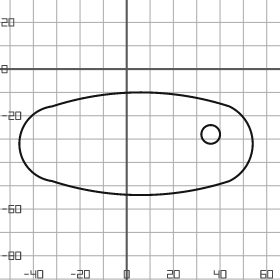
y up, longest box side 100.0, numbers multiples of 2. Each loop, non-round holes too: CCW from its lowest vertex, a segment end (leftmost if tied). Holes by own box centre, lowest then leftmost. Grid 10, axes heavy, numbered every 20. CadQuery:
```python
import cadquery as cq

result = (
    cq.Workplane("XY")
    .moveTo(-32.0, -48.0)
    .threePointArc((6.0, -54.0), (44.0, -48.0))
    .threePointArc((54.0, -32.0), (44.0, -16.0))
    .threePointArc((6.0, -10.0), (-32.0, -16.0))
    .threePointArc((-46.0, -32.0), (-32.0, -48.0))
    .close()
    .moveTo(36.0, -28.0)
    .circle(4.0)
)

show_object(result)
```